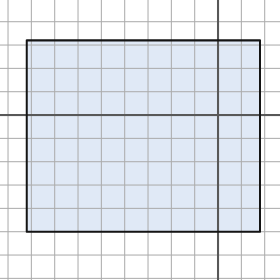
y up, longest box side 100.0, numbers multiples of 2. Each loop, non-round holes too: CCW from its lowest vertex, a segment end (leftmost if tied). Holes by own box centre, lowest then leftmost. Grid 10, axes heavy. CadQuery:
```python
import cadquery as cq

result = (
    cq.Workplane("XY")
    .moveTo(-82.0, -50.0)
    .lineTo(18.0, -50.0)
    .lineTo(18.0, 32.0)
    .lineTo(-82.0, 32.0)
    .close()
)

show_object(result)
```